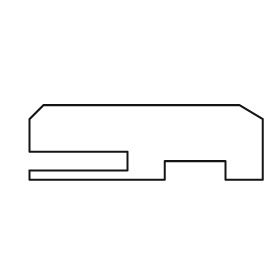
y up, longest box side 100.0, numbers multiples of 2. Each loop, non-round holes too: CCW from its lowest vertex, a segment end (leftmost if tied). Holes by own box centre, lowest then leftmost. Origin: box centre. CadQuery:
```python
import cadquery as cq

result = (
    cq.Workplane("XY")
    .moveTo(-50.0, -16.0)
    .lineTo(8.0, -16.0)
    .lineTo(8.0, -8.0)
    .lineTo(34.0, -8.0)
    .lineTo(34.0, -16.0)
    .lineTo(50.0, -16.0)
    .lineTo(50.0, 10.0)
    .lineTo(40.0, 16.0)
    .lineTo(-44.0, 16.0)
    .lineTo(-50.0, 10.0)
    .lineTo(-50.0, -4.0)
    .lineTo(-8.0, -4.0)
    .lineTo(-8.0, -12.0)
    .lineTo(-50.0, -12.0)
    .close()
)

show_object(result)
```